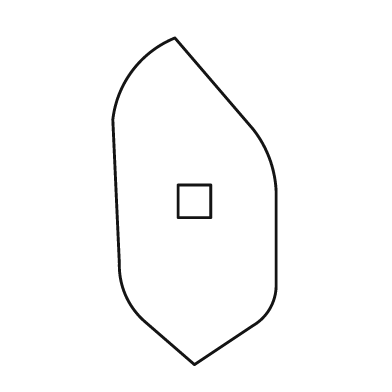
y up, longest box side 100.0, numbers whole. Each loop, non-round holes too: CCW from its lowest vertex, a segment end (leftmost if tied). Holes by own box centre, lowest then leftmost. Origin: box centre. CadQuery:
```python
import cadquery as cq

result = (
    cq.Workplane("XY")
    .moveTo(0.0, -50.0)
    .lineTo(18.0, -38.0)
    .threePointArc((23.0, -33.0), (25.0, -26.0))
    .lineTo(25.0, 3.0)
    .threePointArc((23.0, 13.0), (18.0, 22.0))
    .lineTo(-6.0, 50.0)
    .threePointArc((-19.0, 40.0), (-25.0, 25.0))
    .lineTo(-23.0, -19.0)
    .threePointArc((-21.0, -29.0), (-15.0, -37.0))
    .close()
    .moveTo(-5.0, -5.0)
    .lineTo(5.0, -5.0)
    .lineTo(5.0, 5.0)
    .lineTo(-5.0, 5.0)
    .close()
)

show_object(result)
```